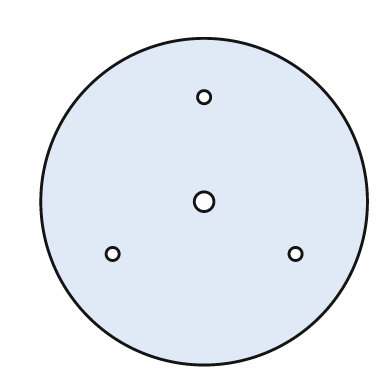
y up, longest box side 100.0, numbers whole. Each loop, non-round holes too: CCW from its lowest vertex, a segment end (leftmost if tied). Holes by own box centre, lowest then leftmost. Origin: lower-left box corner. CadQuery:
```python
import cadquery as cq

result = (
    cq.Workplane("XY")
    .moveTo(50.0, 50.0)
    .circle(50.0)
    .moveTo(22.0, 34.0)
    .circle(2.0)
    .moveTo(78.0, 34.0)
    .circle(2.0)
    .moveTo(50.0, 50.0)
    .circle(3.0)
    .moveTo(50.0, 82.0)
    .circle(2.0)
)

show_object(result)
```